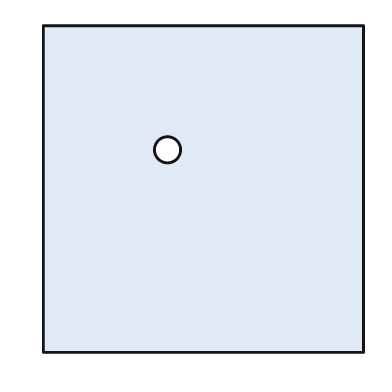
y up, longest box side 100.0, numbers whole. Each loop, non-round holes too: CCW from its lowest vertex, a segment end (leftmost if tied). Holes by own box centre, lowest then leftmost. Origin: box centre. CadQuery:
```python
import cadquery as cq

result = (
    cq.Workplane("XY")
    .moveTo(-49.0, -50.0)
    .lineTo(49.0, -50.0)
    .lineTo(49.0, 50.0)
    .lineTo(-49.0, 50.0)
    .close()
    .moveTo(-11.0, 12.0)
    .circle(4.0)
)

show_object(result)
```